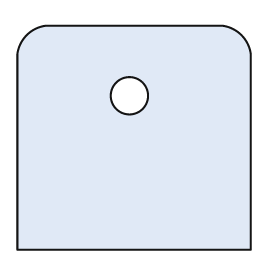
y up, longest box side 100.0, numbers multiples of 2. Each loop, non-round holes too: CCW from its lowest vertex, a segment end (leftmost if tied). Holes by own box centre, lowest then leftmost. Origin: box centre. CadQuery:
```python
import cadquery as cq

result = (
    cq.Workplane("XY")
    .moveTo(-50.0, -48.0)
    .lineTo(50.0, -48.0)
    .lineTo(50.0, 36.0)
    .threePointArc((46.0, 44.0), (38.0, 48.0))
    .lineTo(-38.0, 48.0)
    .threePointArc((-46.0, 44.0), (-50.0, 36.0))
    .close()
    .moveTo(-2.0, 18.0)
    .circle(8.0)
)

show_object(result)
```